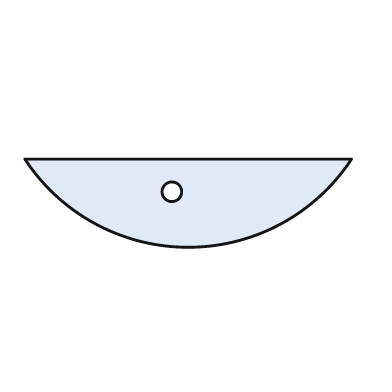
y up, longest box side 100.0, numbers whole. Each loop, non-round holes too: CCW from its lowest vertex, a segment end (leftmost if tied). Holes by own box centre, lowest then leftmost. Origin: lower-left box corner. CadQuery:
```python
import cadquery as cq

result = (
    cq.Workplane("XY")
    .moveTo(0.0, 27.0)
    .threePointArc((50.0, 0.0), (100.0, 27.0))
    .close()
    .moveTo(45.0, 17.0)
    .circle(3.0)
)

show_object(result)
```